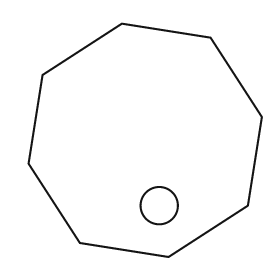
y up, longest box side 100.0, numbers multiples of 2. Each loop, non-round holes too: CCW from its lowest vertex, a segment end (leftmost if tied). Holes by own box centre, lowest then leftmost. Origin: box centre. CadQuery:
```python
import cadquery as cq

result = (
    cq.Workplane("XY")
    .moveTo(10.0, -50.0)
    .lineTo(44.0, -28.0)
    .lineTo(50.0, 10.0)
    .lineTo(28.0, 44.0)
    .lineTo(-10.0, 50.0)
    .lineTo(-44.0, 28.0)
    .lineTo(-50.0, -10.0)
    .lineTo(-28.0, -44.0)
    .close()
    .moveTo(6.0, -28.0)
    .circle(8.0)
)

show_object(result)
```